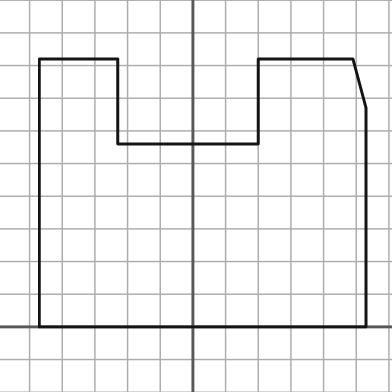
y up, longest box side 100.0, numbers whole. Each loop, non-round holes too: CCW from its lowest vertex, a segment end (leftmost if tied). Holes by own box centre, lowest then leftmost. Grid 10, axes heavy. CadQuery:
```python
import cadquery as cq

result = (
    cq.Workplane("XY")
    .moveTo(-47.0, 0.0)
    .lineTo(53.0, 0.0)
    .lineTo(53.0, 67.0)
    .lineTo(49.0, 82.0)
    .lineTo(20.0, 82.0)
    .lineTo(20.0, 56.0)
    .lineTo(-23.0, 56.0)
    .lineTo(-23.0, 82.0)
    .lineTo(-47.0, 82.0)
    .close()
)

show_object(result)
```